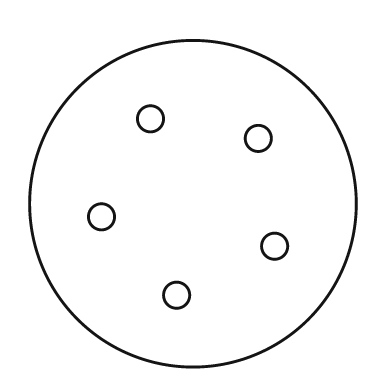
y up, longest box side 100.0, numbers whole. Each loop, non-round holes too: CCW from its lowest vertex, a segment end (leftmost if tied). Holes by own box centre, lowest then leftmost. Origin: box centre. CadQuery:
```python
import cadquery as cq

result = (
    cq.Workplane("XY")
    .moveTo(0.0, 0.0)
    .circle(50.0)
    .moveTo(-5.0, -28.0)
    .circle(4.0)
    .moveTo(25.0, -13.0)
    .circle(4.0)
    .moveTo(-28.0, -4.0)
    .circle(4.0)
    .moveTo(20.0, 20.0)
    .circle(4.0)
    .moveTo(-13.0, 26.0)
    .circle(4.0)
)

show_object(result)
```